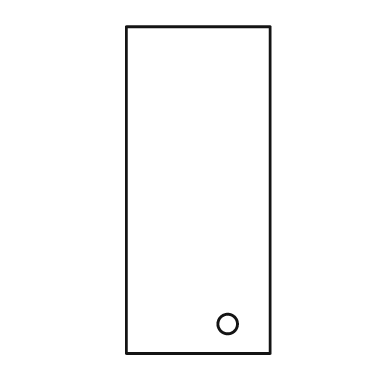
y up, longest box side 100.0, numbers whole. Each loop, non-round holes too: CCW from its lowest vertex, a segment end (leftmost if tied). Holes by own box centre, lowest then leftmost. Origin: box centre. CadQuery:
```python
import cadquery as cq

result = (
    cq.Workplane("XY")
    .moveTo(-22.0, -50.0)
    .lineTo(22.0, -50.0)
    .lineTo(22.0, 50.0)
    .lineTo(-22.0, 50.0)
    .close()
    .moveTo(9.0, -41.0)
    .circle(3.0)
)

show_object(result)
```